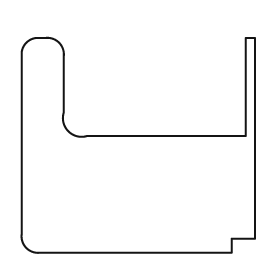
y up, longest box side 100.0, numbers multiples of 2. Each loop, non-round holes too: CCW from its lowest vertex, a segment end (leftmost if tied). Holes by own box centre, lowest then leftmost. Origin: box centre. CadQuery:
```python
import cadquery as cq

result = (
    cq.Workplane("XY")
    .moveTo(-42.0, -46.0)
    .lineTo(40.0, -46.0)
    .lineTo(40.0, -40.0)
    .lineTo(50.0, -40.0)
    .lineTo(50.0, 46.0)
    .lineTo(46.0, 46.0)
    .lineTo(46.0, 4.0)
    .lineTo(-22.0, 4.0)
    .threePointArc((-30.0, 6.0), (-32.0, 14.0))
    .lineTo(-32.0, 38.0)
    .threePointArc((-34.0, 44.0), (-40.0, 46.0))
    .lineTo(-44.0, 46.0)
    .threePointArc((-48.0, 44.0), (-50.0, 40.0))
    .lineTo(-50.0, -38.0)
    .threePointArc((-48.0, -44.0), (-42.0, -46.0))
    .close()
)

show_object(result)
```